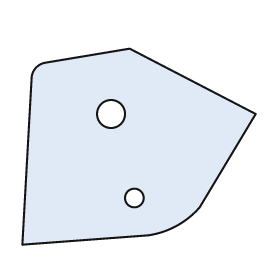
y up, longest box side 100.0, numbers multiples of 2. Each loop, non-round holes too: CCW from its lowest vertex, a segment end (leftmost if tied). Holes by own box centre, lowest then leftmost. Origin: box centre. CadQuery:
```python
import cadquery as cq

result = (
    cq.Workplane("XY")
    .moveTo(-50.0, -42.0)
    .lineTo(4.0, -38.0)
    .threePointArc((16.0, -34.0), (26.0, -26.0))
    .lineTo(50.0, 14.0)
    .lineTo(-4.0, 42.0)
    .lineTo(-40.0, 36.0)
    .threePointArc((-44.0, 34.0), (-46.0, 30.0))
    .close()
    .moveTo(-2.0, -22.0)
    .circle(4.0)
    .moveTo(-12.0, 14.0)
    .circle(6.0)
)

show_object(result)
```